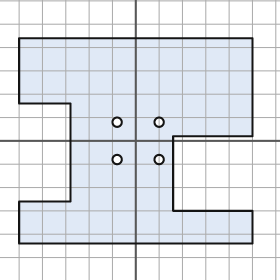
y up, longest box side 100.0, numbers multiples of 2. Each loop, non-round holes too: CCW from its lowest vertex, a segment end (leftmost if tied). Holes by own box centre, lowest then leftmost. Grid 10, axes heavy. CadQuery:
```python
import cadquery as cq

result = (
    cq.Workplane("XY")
    .moveTo(-50.0, -44.0)
    .lineTo(50.0, -44.0)
    .lineTo(50.0, -30.0)
    .lineTo(16.0, -30.0)
    .lineTo(16.0, 2.0)
    .lineTo(50.0, 2.0)
    .lineTo(50.0, 44.0)
    .lineTo(-50.0, 44.0)
    .lineTo(-50.0, 16.0)
    .lineTo(-28.0, 16.0)
    .lineTo(-28.0, -26.0)
    .lineTo(-50.0, -26.0)
    .close()
    .moveTo(-8.0, -8.0)
    .circle(2.0)
    .moveTo(10.0, -8.0)
    .circle(2.0)
    .moveTo(-8.0, 8.0)
    .circle(2.0)
    .moveTo(10.0, 8.0)
    .circle(2.0)
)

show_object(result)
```